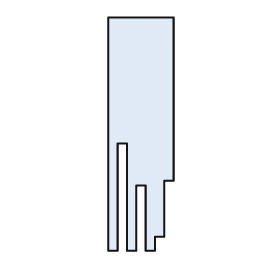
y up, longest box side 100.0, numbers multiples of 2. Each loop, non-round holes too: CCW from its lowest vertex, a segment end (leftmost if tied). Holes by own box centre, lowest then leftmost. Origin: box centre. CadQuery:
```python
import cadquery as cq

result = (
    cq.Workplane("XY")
    .moveTo(-14.0, -50.0)
    .lineTo(-10.0, -50.0)
    .lineTo(-10.0, -4.0)
    .lineTo(-6.0, -4.0)
    .lineTo(-6.0, -50.0)
    .lineTo(-2.0, -50.0)
    .lineTo(-2.0, -22.0)
    .lineTo(2.0, -22.0)
    .lineTo(2.0, -50.0)
    .lineTo(6.0, -50.0)
    .lineTo(6.0, -44.0)
    .lineTo(10.0, -44.0)
    .lineTo(10.0, -20.0)
    .lineTo(14.0, -20.0)
    .lineTo(14.0, 50.0)
    .lineTo(-14.0, 50.0)
    .close()
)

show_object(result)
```